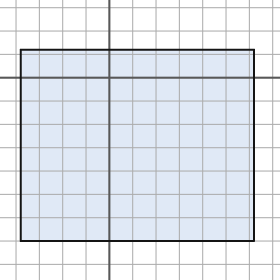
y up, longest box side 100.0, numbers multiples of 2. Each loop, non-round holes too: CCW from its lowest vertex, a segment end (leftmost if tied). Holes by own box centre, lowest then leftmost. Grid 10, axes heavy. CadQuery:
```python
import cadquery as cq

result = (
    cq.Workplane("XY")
    .moveTo(-38.0, -70.0)
    .lineTo(62.0, -70.0)
    .lineTo(62.0, 12.0)
    .lineTo(-38.0, 12.0)
    .close()
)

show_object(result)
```